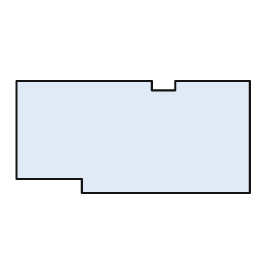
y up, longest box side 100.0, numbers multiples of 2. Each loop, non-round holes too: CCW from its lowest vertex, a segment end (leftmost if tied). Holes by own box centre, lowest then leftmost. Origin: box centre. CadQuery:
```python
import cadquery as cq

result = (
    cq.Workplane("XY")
    .moveTo(-22.0, -24.0)
    .lineTo(50.0, -24.0)
    .lineTo(50.0, 24.0)
    .lineTo(18.0, 24.0)
    .lineTo(18.0, 20.0)
    .lineTo(8.0, 20.0)
    .lineTo(8.0, 24.0)
    .lineTo(-50.0, 24.0)
    .lineTo(-50.0, -18.0)
    .lineTo(-22.0, -18.0)
    .close()
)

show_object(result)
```